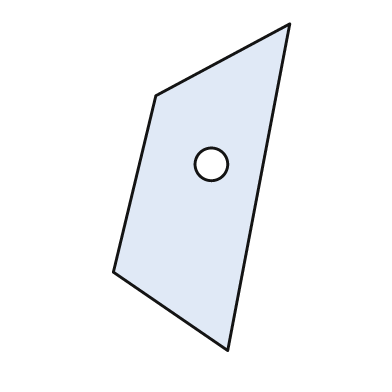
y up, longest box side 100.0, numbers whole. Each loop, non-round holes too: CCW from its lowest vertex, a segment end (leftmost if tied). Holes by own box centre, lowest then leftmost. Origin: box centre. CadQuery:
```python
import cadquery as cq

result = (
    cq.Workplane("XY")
    .moveTo(8.0, -50.0)
    .lineTo(27.0, 50.0)
    .lineTo(-14.0, 28.0)
    .lineTo(-27.0, -26.0)
    .close()
    .moveTo(3.0, 7.0)
    .circle(5.0)
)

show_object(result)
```